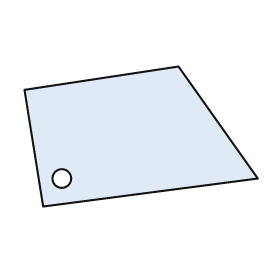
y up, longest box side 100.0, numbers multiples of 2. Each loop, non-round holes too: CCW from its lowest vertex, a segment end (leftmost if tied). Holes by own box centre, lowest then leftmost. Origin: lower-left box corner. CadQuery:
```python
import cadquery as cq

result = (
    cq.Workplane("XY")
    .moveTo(8.0, 0.0)
    .lineTo(100.0, 12.0)
    .lineTo(66.0, 60.0)
    .lineTo(0.0, 50.0)
    .close()
    .moveTo(16.0, 12.0)
    .circle(4.0)
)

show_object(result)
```